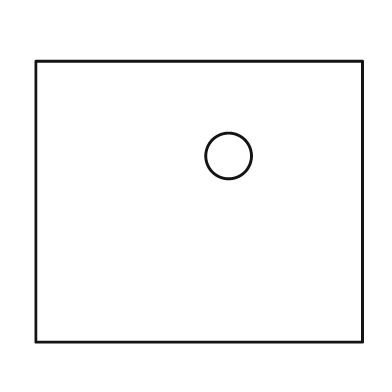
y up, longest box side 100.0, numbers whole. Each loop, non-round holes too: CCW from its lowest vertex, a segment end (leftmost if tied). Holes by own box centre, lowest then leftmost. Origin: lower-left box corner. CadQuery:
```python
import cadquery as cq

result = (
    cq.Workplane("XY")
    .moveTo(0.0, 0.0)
    .lineTo(100.0, 0.0)
    .lineTo(100.0, 86.0)
    .lineTo(0.0, 86.0)
    .close()
    .moveTo(59.0, 57.0)
    .circle(7.0)
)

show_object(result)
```